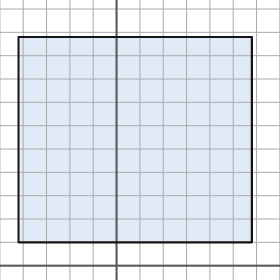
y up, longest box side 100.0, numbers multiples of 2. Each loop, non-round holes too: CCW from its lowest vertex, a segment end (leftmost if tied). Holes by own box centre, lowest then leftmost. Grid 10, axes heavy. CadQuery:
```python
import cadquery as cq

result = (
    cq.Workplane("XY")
    .moveTo(-42.0, 10.0)
    .lineTo(58.0, 10.0)
    .lineTo(58.0, 98.0)
    .lineTo(-42.0, 98.0)
    .close()
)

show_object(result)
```